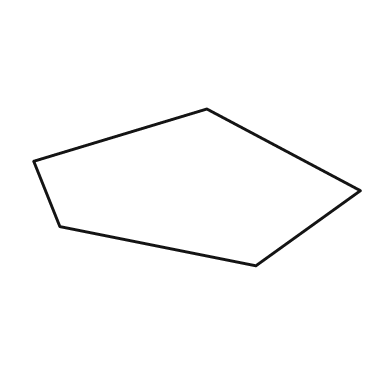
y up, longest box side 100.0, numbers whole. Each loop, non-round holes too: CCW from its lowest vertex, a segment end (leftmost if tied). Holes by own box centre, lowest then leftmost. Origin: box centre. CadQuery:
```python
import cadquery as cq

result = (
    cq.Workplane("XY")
    .moveTo(18.0, -24.0)
    .lineTo(50.0, -1.0)
    .lineTo(3.0, 24.0)
    .lineTo(-50.0, 8.0)
    .lineTo(-42.0, -12.0)
    .close()
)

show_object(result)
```